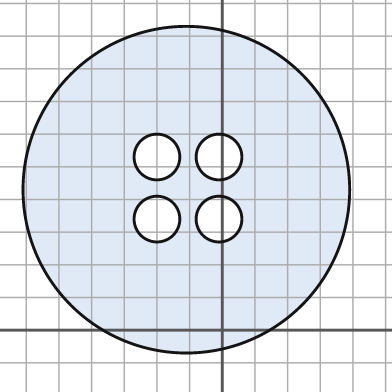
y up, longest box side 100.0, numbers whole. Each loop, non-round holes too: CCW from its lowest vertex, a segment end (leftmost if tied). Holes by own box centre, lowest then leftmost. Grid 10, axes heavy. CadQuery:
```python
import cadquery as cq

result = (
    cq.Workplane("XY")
    .moveTo(-11.0, 43.0)
    .circle(50.0)
    .moveTo(-20.0, 34.0)
    .circle(7.0)
    .moveTo(-1.0, 34.0)
    .circle(7.0)
    .moveTo(-20.0, 53.0)
    .circle(7.0)
    .moveTo(-1.0, 53.0)
    .circle(7.0)
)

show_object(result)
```